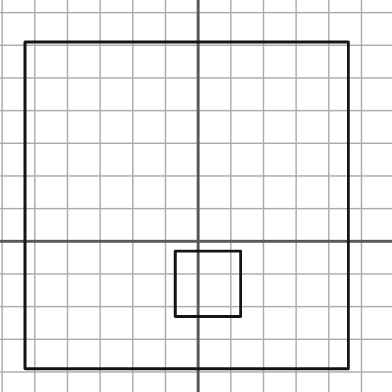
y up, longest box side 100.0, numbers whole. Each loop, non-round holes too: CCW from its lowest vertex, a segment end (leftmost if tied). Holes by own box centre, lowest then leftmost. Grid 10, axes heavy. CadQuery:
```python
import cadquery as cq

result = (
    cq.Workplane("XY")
    .moveTo(-53.0, -39.0)
    .lineTo(46.0, -39.0)
    .lineTo(46.0, 61.0)
    .lineTo(-53.0, 61.0)
    .close()
    .moveTo(-7.0, -23.0)
    .lineTo(13.0, -23.0)
    .lineTo(13.0, -3.0)
    .lineTo(-7.0, -3.0)
    .close()
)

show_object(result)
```